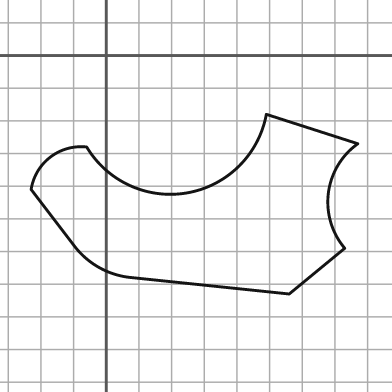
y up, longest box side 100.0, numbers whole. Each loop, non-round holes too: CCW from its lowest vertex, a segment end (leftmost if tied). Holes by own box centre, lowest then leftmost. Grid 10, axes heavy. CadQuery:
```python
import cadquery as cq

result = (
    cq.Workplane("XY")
    .moveTo(56.0, -73.0)
    .lineTo(73.0, -59.0)
    .threePointArc((68.0, -42.0), (77.0, -27.0))
    .lineTo(49.0, -18.0)
    .threePointArc((25.0, -42.0), (-6.0, -28.0))
    .threePointArc((-17.0, -31.0), (-23.0, -41.0))
    .lineTo(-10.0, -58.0)
    .threePointArc((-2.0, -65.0), (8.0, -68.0))
    .close()
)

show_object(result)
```